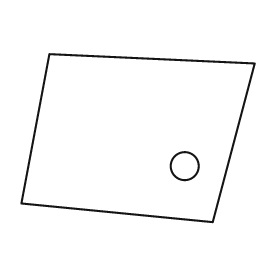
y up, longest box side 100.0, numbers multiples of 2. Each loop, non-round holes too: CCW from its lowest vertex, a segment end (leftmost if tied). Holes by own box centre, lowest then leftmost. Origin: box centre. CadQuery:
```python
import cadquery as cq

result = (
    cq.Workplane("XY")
    .moveTo(32.0, -36.0)
    .lineTo(50.0, 32.0)
    .lineTo(-38.0, 36.0)
    .lineTo(-50.0, -28.0)
    .close()
    .moveTo(20.0, -12.0)
    .circle(6.0)
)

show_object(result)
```